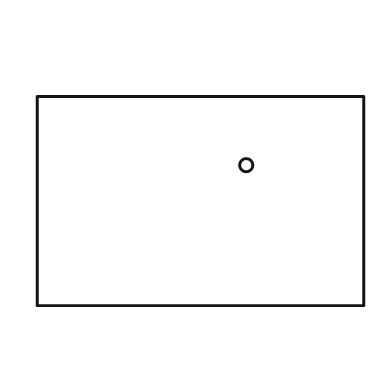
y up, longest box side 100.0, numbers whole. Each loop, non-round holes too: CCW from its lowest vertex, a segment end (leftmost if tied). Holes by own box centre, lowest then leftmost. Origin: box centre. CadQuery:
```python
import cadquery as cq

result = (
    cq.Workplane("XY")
    .moveTo(-50.0, -32.0)
    .lineTo(50.0, -32.0)
    .lineTo(50.0, 32.0)
    .lineTo(-50.0, 32.0)
    .close()
    .moveTo(14.0, 11.0)
    .circle(2.0)
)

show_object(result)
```